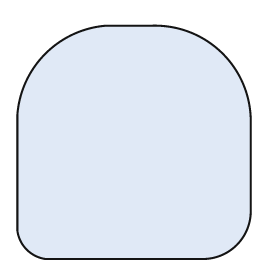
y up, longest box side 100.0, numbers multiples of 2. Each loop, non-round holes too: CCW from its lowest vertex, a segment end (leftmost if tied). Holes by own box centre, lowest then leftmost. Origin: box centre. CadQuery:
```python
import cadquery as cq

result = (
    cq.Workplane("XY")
    .moveTo(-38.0, -50.0)
    .lineTo(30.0, -50.0)
    .threePointArc((44.0, -44.0), (50.0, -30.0))
    .lineTo(50.0, 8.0)
    .threePointArc((38.0, 38.0), (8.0, 50.0))
    .lineTo(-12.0, 50.0)
    .threePointArc((-38.0, 38.0), (-50.0, 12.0))
    .lineTo(-50.0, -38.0)
    .threePointArc((-46.0, -46.0), (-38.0, -50.0))
    .close()
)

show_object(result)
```